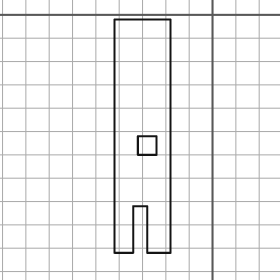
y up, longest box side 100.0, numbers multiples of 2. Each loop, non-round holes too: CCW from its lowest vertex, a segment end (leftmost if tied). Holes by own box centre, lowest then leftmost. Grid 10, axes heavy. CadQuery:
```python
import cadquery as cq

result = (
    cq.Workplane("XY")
    .moveTo(-42.0, -102.0)
    .lineTo(-34.0, -102.0)
    .lineTo(-34.0, -82.0)
    .lineTo(-28.0, -82.0)
    .lineTo(-28.0, -102.0)
    .lineTo(-18.0, -102.0)
    .lineTo(-18.0, -2.0)
    .lineTo(-42.0, -2.0)
    .close()
    .moveTo(-32.0, -60.0)
    .lineTo(-24.0, -60.0)
    .lineTo(-24.0, -52.0)
    .lineTo(-32.0, -52.0)
    .close()
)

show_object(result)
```